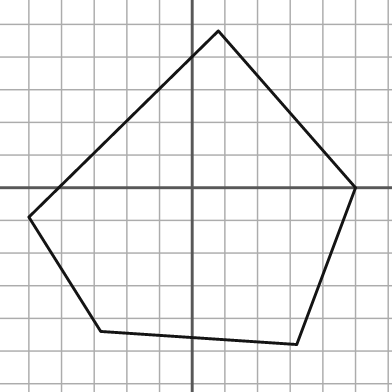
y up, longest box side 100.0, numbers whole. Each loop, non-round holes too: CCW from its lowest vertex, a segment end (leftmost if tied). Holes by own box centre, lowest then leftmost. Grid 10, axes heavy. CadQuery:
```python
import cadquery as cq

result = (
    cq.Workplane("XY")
    .moveTo(32.0, -48.0)
    .lineTo(50.0, 0.0)
    .lineTo(8.0, 48.0)
    .lineTo(-50.0, -9.0)
    .lineTo(-28.0, -44.0)
    .close()
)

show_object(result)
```